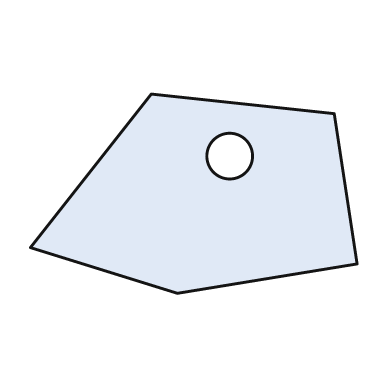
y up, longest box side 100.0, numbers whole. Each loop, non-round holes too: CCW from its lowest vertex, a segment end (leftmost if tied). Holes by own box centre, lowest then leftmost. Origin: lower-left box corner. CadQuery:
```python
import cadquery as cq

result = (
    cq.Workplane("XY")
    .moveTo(45.0, 0.0)
    .lineTo(100.0, 9.0)
    .lineTo(93.0, 55.0)
    .lineTo(37.0, 61.0)
    .lineTo(0.0, 14.0)
    .close()
    .moveTo(61.0, 42.0)
    .circle(7.0)
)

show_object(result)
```